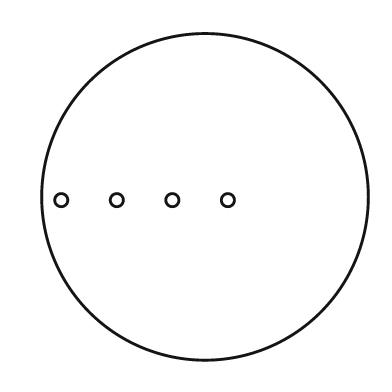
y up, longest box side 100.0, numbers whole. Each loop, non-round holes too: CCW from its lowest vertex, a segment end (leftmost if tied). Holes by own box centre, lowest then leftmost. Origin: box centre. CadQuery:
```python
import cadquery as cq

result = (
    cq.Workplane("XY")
    .moveTo(0.0, 0.0)
    .circle(50.0)
    .moveTo(-44.0, -1.0)
    .circle(2.0)
    .moveTo(-27.0, -1.0)
    .circle(2.0)
    .moveTo(-10.0, -1.0)
    .circle(2.0)
    .moveTo(7.0, -1.0)
    .circle(2.0)
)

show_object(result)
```